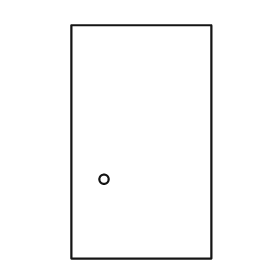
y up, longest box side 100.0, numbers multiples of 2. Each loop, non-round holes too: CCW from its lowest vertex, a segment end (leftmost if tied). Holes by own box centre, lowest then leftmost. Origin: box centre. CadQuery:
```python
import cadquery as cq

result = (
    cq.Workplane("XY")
    .moveTo(-30.0, -50.0)
    .lineTo(30.0, -50.0)
    .lineTo(30.0, 50.0)
    .lineTo(-30.0, 50.0)
    .close()
    .moveTo(-16.0, -16.0)
    .circle(2.0)
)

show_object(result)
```